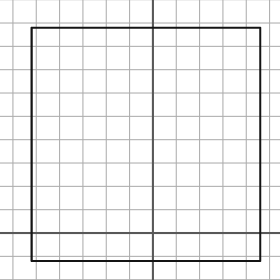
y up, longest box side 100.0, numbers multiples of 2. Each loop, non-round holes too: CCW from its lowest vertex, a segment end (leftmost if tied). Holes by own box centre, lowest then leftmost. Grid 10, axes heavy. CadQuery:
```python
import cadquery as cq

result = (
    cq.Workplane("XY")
    .moveTo(-52.0, -12.0)
    .lineTo(46.0, -12.0)
    .lineTo(46.0, 88.0)
    .lineTo(-52.0, 88.0)
    .close()
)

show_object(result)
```